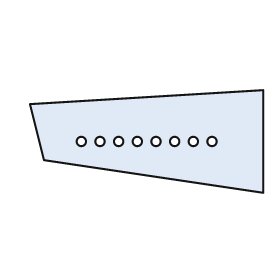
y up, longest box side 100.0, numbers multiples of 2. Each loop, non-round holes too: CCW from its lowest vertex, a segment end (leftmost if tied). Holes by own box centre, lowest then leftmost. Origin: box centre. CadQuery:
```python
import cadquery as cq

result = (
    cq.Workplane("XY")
    .moveTo(50.0, -22.0)
    .lineTo(50.0, 22.0)
    .lineTo(-50.0, 16.0)
    .lineTo(-44.0, -8.0)
    .close()
    .moveTo(-28.0, 0.0)
    .circle(2.0)
    .moveTo(-20.0, 0.0)
    .circle(2.0)
    .moveTo(-12.0, 0.0)
    .circle(2.0)
    .moveTo(-4.0, 0.0)
    .circle(2.0)
    .moveTo(4.0, 0.0)
    .circle(2.0)
    .moveTo(12.0, 0.0)
    .circle(2.0)
    .moveTo(20.0, 0.0)
    .circle(2.0)
    .moveTo(28.0, 0.0)
    .circle(2.0)
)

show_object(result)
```